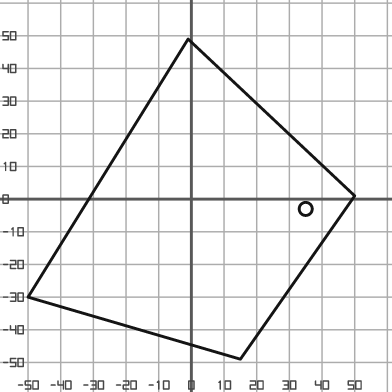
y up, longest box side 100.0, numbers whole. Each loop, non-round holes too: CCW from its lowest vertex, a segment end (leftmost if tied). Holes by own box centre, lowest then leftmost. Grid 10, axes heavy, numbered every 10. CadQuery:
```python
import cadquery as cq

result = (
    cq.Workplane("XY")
    .moveTo(15.0, -49.0)
    .lineTo(50.0, 1.0)
    .lineTo(-1.0, 49.0)
    .lineTo(-50.0, -30.0)
    .close()
    .moveTo(35.0, -3.0)
    .circle(2.0)
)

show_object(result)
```